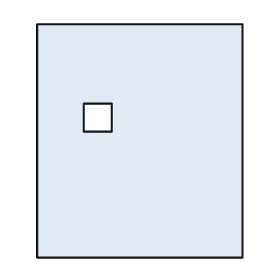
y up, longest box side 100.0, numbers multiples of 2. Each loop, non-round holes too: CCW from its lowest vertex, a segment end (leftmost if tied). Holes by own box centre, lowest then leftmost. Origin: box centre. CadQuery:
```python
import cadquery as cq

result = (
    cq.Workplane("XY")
    .moveTo(-44.0, -50.0)
    .lineTo(44.0, -50.0)
    .lineTo(44.0, 50.0)
    .lineTo(-44.0, 50.0)
    .close()
    .moveTo(-24.0, 4.0)
    .lineTo(-12.0, 4.0)
    .lineTo(-12.0, 16.0)
    .lineTo(-24.0, 16.0)
    .close()
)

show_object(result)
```